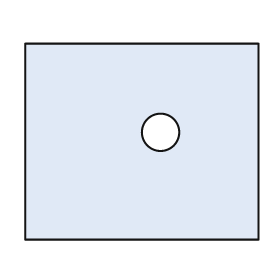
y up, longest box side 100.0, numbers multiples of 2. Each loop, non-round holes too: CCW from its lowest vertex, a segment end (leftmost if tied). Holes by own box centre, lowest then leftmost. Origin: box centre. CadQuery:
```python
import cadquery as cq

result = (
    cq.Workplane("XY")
    .moveTo(-50.0, -42.0)
    .lineTo(50.0, -42.0)
    .lineTo(50.0, 42.0)
    .lineTo(-50.0, 42.0)
    .close()
    .moveTo(8.0, 4.0)
    .circle(8.0)
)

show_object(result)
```